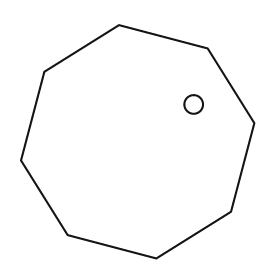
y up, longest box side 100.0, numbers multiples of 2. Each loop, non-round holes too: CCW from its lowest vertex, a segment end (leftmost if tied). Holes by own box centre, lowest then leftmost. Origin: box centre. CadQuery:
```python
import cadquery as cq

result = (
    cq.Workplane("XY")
    .moveTo(8.0, -50.0)
    .lineTo(40.0, -30.0)
    .lineTo(50.0, 8.0)
    .lineTo(30.0, 40.0)
    .lineTo(-8.0, 50.0)
    .lineTo(-40.0, 30.0)
    .lineTo(-50.0, -8.0)
    .lineTo(-30.0, -40.0)
    .close()
    .moveTo(24.0, 16.0)
    .circle(4.0)
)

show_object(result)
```